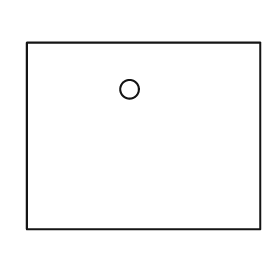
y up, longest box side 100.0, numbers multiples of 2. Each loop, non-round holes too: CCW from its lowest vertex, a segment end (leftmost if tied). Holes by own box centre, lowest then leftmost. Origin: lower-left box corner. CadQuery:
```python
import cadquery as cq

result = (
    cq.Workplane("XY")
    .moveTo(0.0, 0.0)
    .lineTo(100.0, 0.0)
    .lineTo(100.0, 80.0)
    .lineTo(0.0, 80.0)
    .close()
    .moveTo(44.0, 60.0)
    .circle(4.0)
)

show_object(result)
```